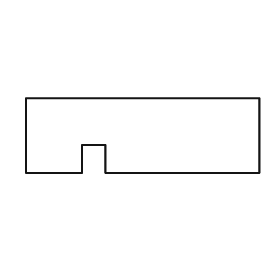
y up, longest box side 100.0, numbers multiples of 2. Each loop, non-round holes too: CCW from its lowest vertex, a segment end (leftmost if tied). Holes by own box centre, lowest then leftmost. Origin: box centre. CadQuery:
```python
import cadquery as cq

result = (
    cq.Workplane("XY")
    .moveTo(-50.0, -16.0)
    .lineTo(-26.0, -16.0)
    .lineTo(-26.0, -4.0)
    .lineTo(-16.0, -4.0)
    .lineTo(-16.0, -16.0)
    .lineTo(50.0, -16.0)
    .lineTo(50.0, 16.0)
    .lineTo(-50.0, 16.0)
    .close()
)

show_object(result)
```